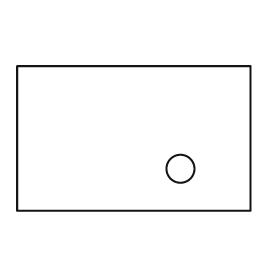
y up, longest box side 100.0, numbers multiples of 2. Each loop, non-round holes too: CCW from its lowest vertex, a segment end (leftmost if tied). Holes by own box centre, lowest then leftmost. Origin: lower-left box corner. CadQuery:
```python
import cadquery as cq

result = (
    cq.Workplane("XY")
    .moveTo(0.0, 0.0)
    .lineTo(100.0, 0.0)
    .lineTo(100.0, 62.0)
    .lineTo(0.0, 62.0)
    .close()
    .moveTo(70.0, 18.0)
    .circle(6.0)
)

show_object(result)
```